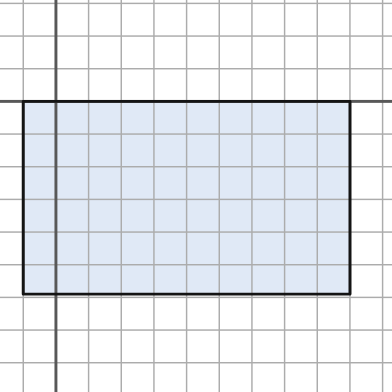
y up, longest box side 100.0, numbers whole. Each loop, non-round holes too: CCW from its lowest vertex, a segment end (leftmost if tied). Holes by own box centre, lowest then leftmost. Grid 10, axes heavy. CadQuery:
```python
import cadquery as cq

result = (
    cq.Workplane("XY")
    .moveTo(-10.0, -59.0)
    .lineTo(90.0, -59.0)
    .lineTo(90.0, 0.0)
    .lineTo(-10.0, 0.0)
    .close()
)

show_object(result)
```